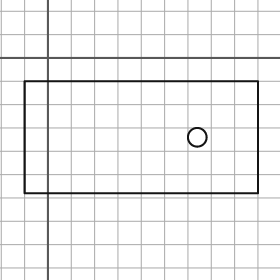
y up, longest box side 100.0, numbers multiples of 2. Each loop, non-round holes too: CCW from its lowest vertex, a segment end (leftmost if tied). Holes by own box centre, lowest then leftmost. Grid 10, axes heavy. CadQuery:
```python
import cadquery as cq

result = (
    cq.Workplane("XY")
    .moveTo(-10.0, -58.0)
    .lineTo(90.0, -58.0)
    .lineTo(90.0, -10.0)
    .lineTo(-10.0, -10.0)
    .close()
    .moveTo(64.0, -34.0)
    .circle(4.0)
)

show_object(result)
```